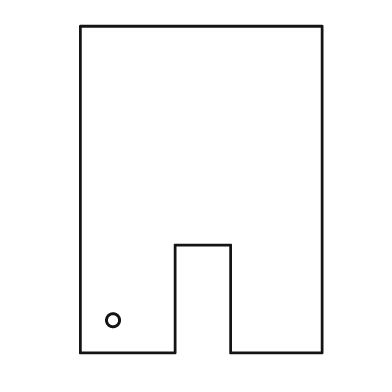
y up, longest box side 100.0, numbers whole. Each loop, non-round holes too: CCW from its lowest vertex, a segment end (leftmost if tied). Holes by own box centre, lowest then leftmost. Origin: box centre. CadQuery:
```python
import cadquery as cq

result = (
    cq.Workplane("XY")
    .moveTo(-37.0, -50.0)
    .lineTo(-8.0, -50.0)
    .lineTo(-8.0, -17.0)
    .lineTo(9.0, -17.0)
    .lineTo(9.0, -50.0)
    .lineTo(37.0, -50.0)
    .lineTo(37.0, 50.0)
    .lineTo(-37.0, 50.0)
    .close()
    .moveTo(-27.0, -40.0)
    .circle(2.0)
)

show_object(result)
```